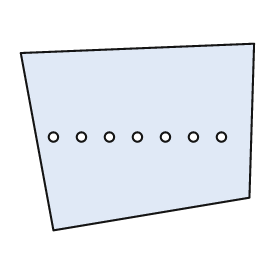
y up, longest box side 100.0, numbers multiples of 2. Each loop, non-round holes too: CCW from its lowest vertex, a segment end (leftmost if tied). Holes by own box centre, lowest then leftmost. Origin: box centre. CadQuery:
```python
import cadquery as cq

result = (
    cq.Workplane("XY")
    .moveTo(-36.0, -40.0)
    .lineTo(48.0, -26.0)
    .lineTo(50.0, 40.0)
    .lineTo(-50.0, 36.0)
    .close()
    .moveTo(-36.0, 0.0)
    .circle(2.0)
    .moveTo(-24.0, 0.0)
    .circle(2.0)
    .moveTo(-12.0, 0.0)
    .circle(2.0)
    .moveTo(0.0, 0.0)
    .circle(2.0)
    .moveTo(12.0, 0.0)
    .circle(2.0)
    .moveTo(24.0, 0.0)
    .circle(2.0)
    .moveTo(36.0, 0.0)
    .circle(2.0)
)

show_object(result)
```